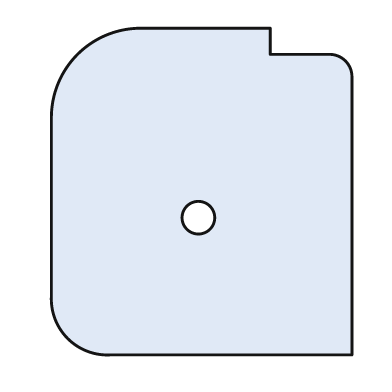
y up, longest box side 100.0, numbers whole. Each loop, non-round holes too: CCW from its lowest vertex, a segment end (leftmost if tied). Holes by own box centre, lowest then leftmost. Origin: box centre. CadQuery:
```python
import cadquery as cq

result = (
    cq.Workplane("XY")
    .moveTo(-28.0, -50.0)
    .lineTo(46.0, -50.0)
    .lineTo(46.0, 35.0)
    .threePointArc((44.0, 40.0), (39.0, 42.0))
    .lineTo(21.0, 42.0)
    .lineTo(21.0, 50.0)
    .lineTo(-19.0, 50.0)
    .threePointArc((-38.0, 42.0), (-46.0, 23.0))
    .lineTo(-46.0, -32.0)
    .threePointArc((-41.0, -45.0), (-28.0, -50.0))
    .close()
    .moveTo(-1.0, -8.0)
    .circle(5.0)
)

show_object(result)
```